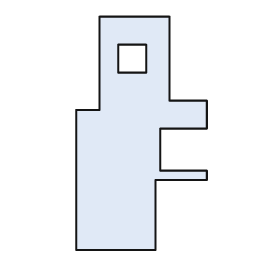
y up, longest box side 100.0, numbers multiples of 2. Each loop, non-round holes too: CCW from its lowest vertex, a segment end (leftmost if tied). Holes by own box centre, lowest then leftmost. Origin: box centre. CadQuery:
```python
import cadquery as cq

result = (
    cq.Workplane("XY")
    .moveTo(-28.0, -50.0)
    .lineTo(6.0, -50.0)
    .lineTo(6.0, -20.0)
    .lineTo(28.0, -20.0)
    .lineTo(28.0, -16.0)
    .lineTo(8.0, -16.0)
    .lineTo(8.0, 2.0)
    .lineTo(28.0, 2.0)
    .lineTo(28.0, 14.0)
    .lineTo(12.0, 14.0)
    .lineTo(12.0, 50.0)
    .lineTo(-18.0, 50.0)
    .lineTo(-18.0, 10.0)
    .lineTo(-28.0, 10.0)
    .close()
    .moveTo(-10.0, 26.0)
    .lineTo(2.0, 26.0)
    .lineTo(2.0, 38.0)
    .lineTo(-10.0, 38.0)
    .close()
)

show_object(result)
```